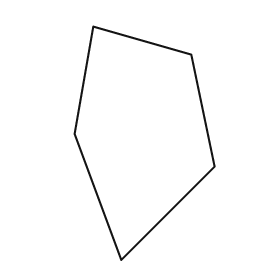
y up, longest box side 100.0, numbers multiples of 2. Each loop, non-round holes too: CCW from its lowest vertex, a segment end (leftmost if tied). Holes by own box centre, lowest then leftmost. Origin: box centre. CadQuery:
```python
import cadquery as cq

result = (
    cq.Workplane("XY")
    .moveTo(-10.0, -50.0)
    .lineTo(30.0, -10.0)
    .lineTo(20.0, 38.0)
    .lineTo(-22.0, 50.0)
    .lineTo(-30.0, 4.0)
    .close()
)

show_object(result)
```